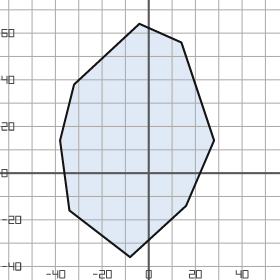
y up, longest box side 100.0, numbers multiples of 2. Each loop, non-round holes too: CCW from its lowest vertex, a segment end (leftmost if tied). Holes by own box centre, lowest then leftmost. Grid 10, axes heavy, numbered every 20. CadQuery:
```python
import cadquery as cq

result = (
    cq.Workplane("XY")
    .moveTo(-8.0, -36.0)
    .lineTo(16.0, -14.0)
    .lineTo(28.0, 14.0)
    .lineTo(14.0, 56.0)
    .lineTo(-4.0, 64.0)
    .lineTo(-32.0, 38.0)
    .lineTo(-38.0, 14.0)
    .lineTo(-34.0, -16.0)
    .close()
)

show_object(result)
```